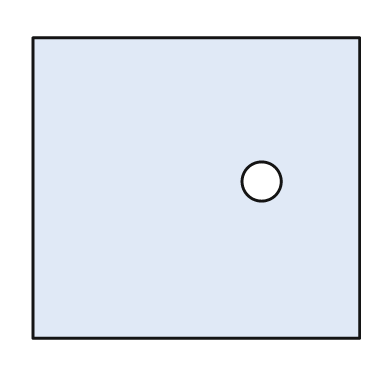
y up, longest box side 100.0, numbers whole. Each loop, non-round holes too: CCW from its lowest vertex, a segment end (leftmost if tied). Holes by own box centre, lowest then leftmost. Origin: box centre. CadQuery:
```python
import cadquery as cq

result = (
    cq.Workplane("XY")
    .moveTo(-50.0, -46.0)
    .lineTo(50.0, -46.0)
    .lineTo(50.0, 46.0)
    .lineTo(-50.0, 46.0)
    .close()
    .moveTo(20.0, 2.0)
    .circle(6.0)
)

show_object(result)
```